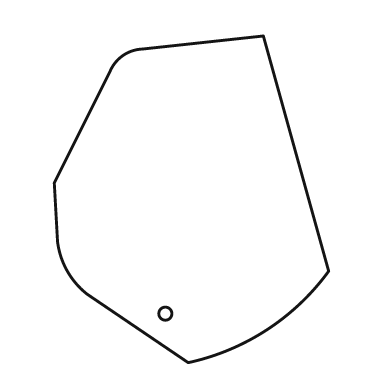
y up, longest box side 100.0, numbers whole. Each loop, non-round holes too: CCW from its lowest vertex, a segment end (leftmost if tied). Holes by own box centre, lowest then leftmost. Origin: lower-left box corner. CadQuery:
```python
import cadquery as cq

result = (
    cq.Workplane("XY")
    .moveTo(41.0, 0.0)
    .threePointArc((65.0, 10.0), (84.0, 28.0))
    .lineTo(64.0, 100.0)
    .lineTo(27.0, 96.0)
    .threePointArc((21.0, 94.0), (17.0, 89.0))
    .lineTo(0.0, 55.0)
    .lineTo(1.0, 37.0)
    .threePointArc((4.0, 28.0), (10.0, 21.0))
    .close()
    .moveTo(34.0, 15.0)
    .circle(2.0)
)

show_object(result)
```